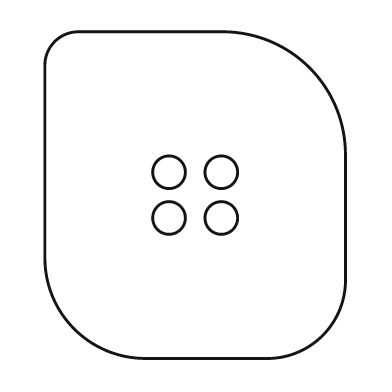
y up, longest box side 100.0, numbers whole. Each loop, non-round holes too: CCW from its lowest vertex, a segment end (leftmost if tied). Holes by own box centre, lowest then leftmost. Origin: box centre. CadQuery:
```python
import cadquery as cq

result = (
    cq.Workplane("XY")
    .moveTo(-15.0, -50.0)
    .lineTo(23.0, -50.0)
    .threePointArc((39.0, -43.0), (46.0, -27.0))
    .lineTo(46.0, 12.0)
    .threePointArc((35.0, 39.0), (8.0, 50.0))
    .lineTo(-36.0, 50.0)
    .threePointArc((-43.0, 47.0), (-46.0, 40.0))
    .lineTo(-46.0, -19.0)
    .threePointArc((-37.0, -41.0), (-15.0, -50.0))
    .close()
    .moveTo(-8.0, -7.0)
    .circle(5.0)
    .moveTo(8.0, -7.0)
    .circle(5.0)
    .moveTo(-8.0, 7.0)
    .circle(5.0)
    .moveTo(8.0, 7.0)
    .circle(5.0)
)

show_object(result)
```